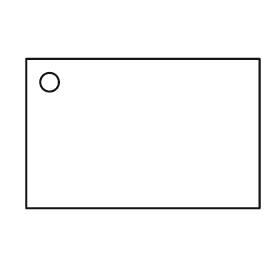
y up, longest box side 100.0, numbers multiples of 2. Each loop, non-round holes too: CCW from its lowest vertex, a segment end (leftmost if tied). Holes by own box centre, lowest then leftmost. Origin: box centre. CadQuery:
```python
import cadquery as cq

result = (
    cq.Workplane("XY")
    .moveTo(-50.0, -32.0)
    .lineTo(50.0, -32.0)
    .lineTo(50.0, 32.0)
    .lineTo(-50.0, 32.0)
    .close()
    .moveTo(-40.0, 22.0)
    .circle(4.0)
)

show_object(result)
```